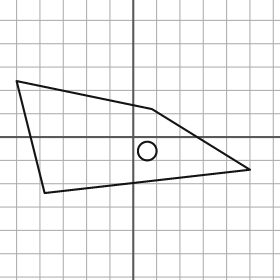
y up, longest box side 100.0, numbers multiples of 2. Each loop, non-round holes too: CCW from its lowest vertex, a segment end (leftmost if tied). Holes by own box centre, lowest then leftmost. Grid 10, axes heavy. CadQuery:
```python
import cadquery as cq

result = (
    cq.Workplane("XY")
    .moveTo(-38.0, -24.0)
    .lineTo(50.0, -14.0)
    .lineTo(8.0, 12.0)
    .lineTo(-50.0, 24.0)
    .close()
    .moveTo(6.0, -6.0)
    .circle(4.0)
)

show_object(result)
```